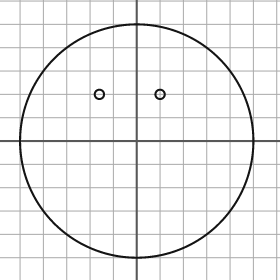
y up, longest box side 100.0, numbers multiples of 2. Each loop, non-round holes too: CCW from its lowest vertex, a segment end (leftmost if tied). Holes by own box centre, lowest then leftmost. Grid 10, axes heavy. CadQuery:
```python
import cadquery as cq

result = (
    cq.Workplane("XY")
    .moveTo(0.0, 0.0)
    .circle(50.0)
    .moveTo(-16.0, 20.0)
    .circle(2.0)
    .moveTo(10.0, 20.0)
    .circle(2.0)
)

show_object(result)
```